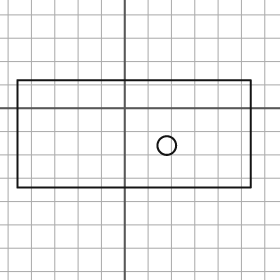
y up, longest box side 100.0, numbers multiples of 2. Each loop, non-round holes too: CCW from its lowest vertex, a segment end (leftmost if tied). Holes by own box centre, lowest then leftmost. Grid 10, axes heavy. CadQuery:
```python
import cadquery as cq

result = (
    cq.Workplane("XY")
    .moveTo(-46.0, -34.0)
    .lineTo(54.0, -34.0)
    .lineTo(54.0, 12.0)
    .lineTo(-46.0, 12.0)
    .close()
    .moveTo(18.0, -16.0)
    .circle(4.0)
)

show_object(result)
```